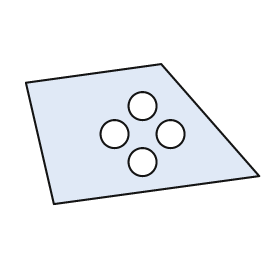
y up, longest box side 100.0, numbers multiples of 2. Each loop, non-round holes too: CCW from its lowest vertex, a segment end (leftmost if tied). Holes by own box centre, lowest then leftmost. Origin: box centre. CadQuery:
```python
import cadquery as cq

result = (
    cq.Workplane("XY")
    .moveTo(-38.0, -30.0)
    .lineTo(50.0, -18.0)
    .lineTo(8.0, 30.0)
    .lineTo(-50.0, 22.0)
    .close()
    .moveTo(0.0, -12.0)
    .circle(6.0)
    .moveTo(-12.0, 0.0)
    .circle(6.0)
    .moveTo(12.0, 0.0)
    .circle(6.0)
    .moveTo(0.0, 12.0)
    .circle(6.0)
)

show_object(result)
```